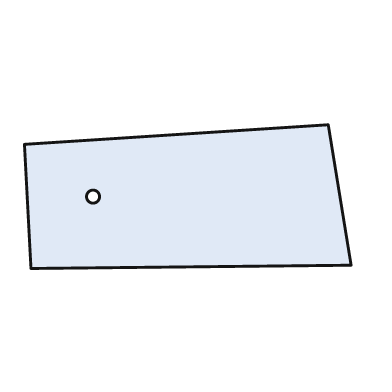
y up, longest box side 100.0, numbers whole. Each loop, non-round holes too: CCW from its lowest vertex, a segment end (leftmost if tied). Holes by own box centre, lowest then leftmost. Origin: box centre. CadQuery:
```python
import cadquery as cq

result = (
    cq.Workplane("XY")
    .moveTo(-48.0, -22.0)
    .lineTo(50.0, -21.0)
    .lineTo(43.0, 22.0)
    .lineTo(-50.0, 16.0)
    .close()
    .moveTo(-29.0, 0.0)
    .circle(2.0)
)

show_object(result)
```